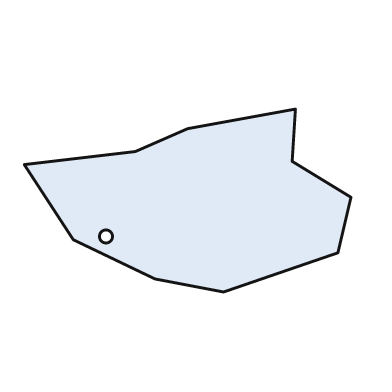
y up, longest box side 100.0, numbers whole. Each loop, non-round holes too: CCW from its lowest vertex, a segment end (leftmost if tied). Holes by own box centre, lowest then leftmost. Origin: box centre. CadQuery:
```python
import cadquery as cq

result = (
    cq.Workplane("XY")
    .moveTo(11.0, -28.0)
    .lineTo(46.0, -16.0)
    .lineTo(50.0, 1.0)
    .lineTo(32.0, 12.0)
    .lineTo(33.0, 28.0)
    .lineTo(0.0, 22.0)
    .lineTo(-16.0, 15.0)
    .lineTo(-50.0, 11.0)
    .lineTo(-35.0, -12.0)
    .lineTo(-10.0, -24.0)
    .close()
    .moveTo(-25.0, -11.0)
    .circle(2.0)
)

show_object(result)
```